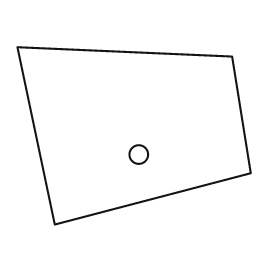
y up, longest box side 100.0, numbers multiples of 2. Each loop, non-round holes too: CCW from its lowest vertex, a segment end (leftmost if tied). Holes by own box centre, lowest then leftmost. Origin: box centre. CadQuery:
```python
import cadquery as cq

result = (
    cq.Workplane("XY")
    .moveTo(-34.0, -38.0)
    .lineTo(50.0, -16.0)
    .lineTo(42.0, 34.0)
    .lineTo(-50.0, 38.0)
    .close()
    .moveTo(2.0, -8.0)
    .circle(4.0)
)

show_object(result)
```